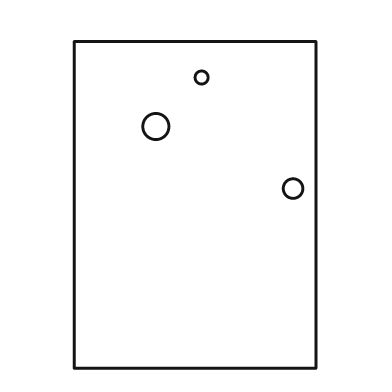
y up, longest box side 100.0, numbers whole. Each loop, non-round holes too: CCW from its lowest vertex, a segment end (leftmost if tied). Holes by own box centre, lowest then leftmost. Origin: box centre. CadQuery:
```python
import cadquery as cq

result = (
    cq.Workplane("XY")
    .moveTo(-37.0, -50.0)
    .lineTo(37.0, -50.0)
    .lineTo(37.0, 50.0)
    .lineTo(-37.0, 50.0)
    .close()
    .moveTo(30.0, 5.0)
    .circle(3.0)
    .moveTo(-12.0, 24.0)
    .circle(4.0)
    .moveTo(2.0, 39.0)
    .circle(2.0)
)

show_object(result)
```